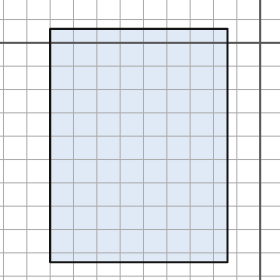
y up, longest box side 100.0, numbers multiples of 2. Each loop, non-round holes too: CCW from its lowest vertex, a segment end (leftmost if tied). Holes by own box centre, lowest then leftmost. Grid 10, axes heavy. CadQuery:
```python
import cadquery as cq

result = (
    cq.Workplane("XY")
    .moveTo(-90.0, -94.0)
    .lineTo(-14.0, -94.0)
    .lineTo(-14.0, 6.0)
    .lineTo(-90.0, 6.0)
    .close()
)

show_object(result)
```